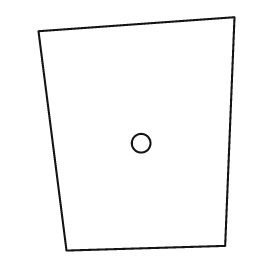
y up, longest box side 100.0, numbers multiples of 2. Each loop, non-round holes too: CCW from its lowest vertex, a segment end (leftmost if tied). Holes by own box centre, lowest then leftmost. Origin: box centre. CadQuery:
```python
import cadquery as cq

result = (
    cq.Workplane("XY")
    .moveTo(-30.0, -50.0)
    .lineTo(38.0, -48.0)
    .lineTo(42.0, 50.0)
    .lineTo(-42.0, 44.0)
    .close()
    .moveTo(2.0, -4.0)
    .circle(4.0)
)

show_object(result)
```